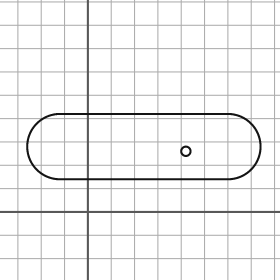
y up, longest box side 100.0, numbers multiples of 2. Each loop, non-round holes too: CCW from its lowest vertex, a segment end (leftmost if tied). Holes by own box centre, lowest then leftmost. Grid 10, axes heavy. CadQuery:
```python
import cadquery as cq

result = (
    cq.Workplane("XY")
    .moveTo(-12.0, 14.0)
    .lineTo(60.0, 14.0)
    .threePointArc((74.0, 28.0), (60.0, 42.0))
    .lineTo(-12.0, 42.0)
    .threePointArc((-26.0, 28.0), (-12.0, 14.0))
    .close()
    .moveTo(42.0, 26.0)
    .circle(2.0)
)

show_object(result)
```